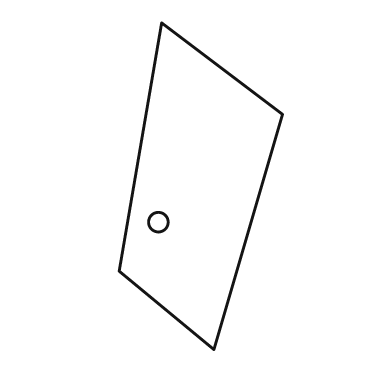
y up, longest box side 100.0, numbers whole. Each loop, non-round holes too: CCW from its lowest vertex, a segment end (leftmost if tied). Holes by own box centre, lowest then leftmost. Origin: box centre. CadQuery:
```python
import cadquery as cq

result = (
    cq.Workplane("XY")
    .moveTo(4.0, -50.0)
    .lineTo(25.0, 22.0)
    .lineTo(-12.0, 50.0)
    .lineTo(-25.0, -26.0)
    .close()
    .moveTo(-13.0, -11.0)
    .circle(3.0)
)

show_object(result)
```